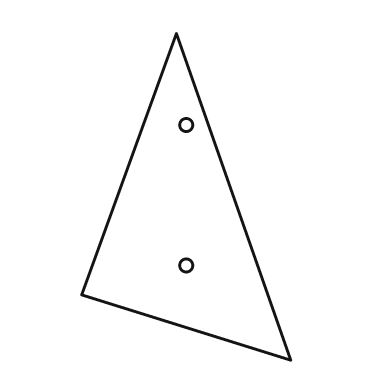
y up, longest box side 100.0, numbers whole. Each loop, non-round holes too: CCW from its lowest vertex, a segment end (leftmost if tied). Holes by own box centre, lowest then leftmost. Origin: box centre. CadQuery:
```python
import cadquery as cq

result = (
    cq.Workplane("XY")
    .moveTo(32.0, -50.0)
    .lineTo(-3.0, 50.0)
    .lineTo(-32.0, -30.0)
    .close()
    .moveTo(0.0, -21.0)
    .circle(2.0)
    .moveTo(0.0, 22.0)
    .circle(2.0)
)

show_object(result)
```